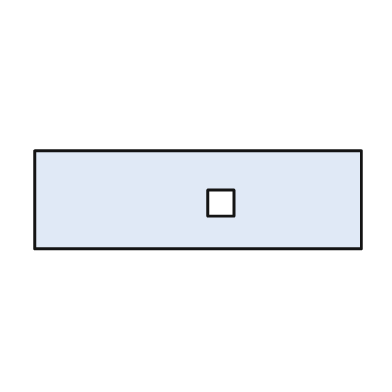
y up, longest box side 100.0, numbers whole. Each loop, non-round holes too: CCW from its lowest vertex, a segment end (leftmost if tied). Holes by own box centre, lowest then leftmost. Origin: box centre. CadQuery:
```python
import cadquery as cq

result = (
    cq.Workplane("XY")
    .moveTo(-50.0, -15.0)
    .lineTo(50.0, -15.0)
    .lineTo(50.0, 15.0)
    .lineTo(-50.0, 15.0)
    .close()
    .moveTo(3.0, -5.0)
    .lineTo(11.0, -5.0)
    .lineTo(11.0, 3.0)
    .lineTo(3.0, 3.0)
    .close()
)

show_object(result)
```